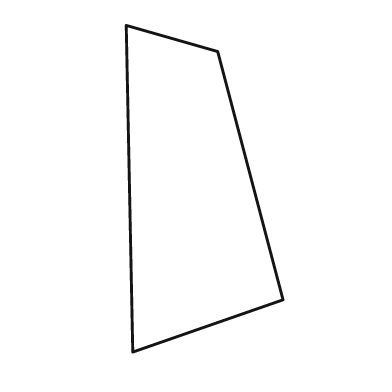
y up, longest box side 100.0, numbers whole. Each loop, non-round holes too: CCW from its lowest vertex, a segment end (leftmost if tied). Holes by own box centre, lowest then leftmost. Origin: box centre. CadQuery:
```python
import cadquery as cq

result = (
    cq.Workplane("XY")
    .moveTo(-22.0, -50.0)
    .lineTo(24.0, -34.0)
    .lineTo(4.0, 42.0)
    .lineTo(-24.0, 50.0)
    .close()
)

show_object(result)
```